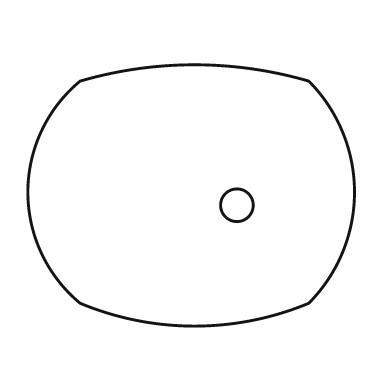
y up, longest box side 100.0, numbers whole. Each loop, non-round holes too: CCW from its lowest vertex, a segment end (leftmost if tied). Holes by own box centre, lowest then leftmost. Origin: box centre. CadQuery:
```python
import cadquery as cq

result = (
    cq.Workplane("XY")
    .moveTo(-34.0, -33.0)
    .threePointArc((1.0, -40.0), (36.0, -33.0))
    .threePointArc((50.0, 1.0), (36.0, 35.0))
    .threePointArc((1.0, 40.0), (-34.0, 35.0))
    .threePointArc((-50.0, 1.0), (-34.0, -33.0))
    .close()
    .moveTo(14.0, -3.0)
    .circle(5.0)
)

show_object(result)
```